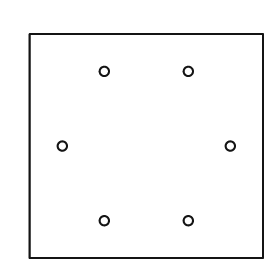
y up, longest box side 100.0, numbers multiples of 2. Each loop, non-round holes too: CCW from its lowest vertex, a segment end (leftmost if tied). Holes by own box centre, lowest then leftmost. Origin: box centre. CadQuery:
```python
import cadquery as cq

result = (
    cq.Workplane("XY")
    .moveTo(-50.0, -48.0)
    .lineTo(50.0, -48.0)
    .lineTo(50.0, 48.0)
    .lineTo(-50.0, 48.0)
    .close()
    .moveTo(-18.0, -32.0)
    .circle(2.0)
    .moveTo(18.0, -32.0)
    .circle(2.0)
    .moveTo(-36.0, 0.0)
    .circle(2.0)
    .moveTo(36.0, 0.0)
    .circle(2.0)
    .moveTo(-18.0, 32.0)
    .circle(2.0)
    .moveTo(18.0, 32.0)
    .circle(2.0)
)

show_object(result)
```